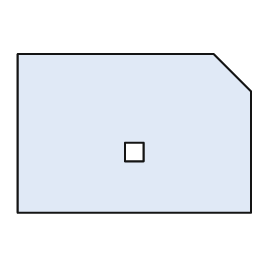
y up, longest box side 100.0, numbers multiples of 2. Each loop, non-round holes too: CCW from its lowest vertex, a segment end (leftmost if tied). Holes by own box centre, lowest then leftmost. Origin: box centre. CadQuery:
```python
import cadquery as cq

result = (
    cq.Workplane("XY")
    .moveTo(-50.0, -34.0)
    .lineTo(50.0, -34.0)
    .lineTo(50.0, 18.0)
    .lineTo(34.0, 34.0)
    .lineTo(-50.0, 34.0)
    .close()
    .moveTo(-4.0, -12.0)
    .lineTo(4.0, -12.0)
    .lineTo(4.0, -4.0)
    .lineTo(-4.0, -4.0)
    .close()
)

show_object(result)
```